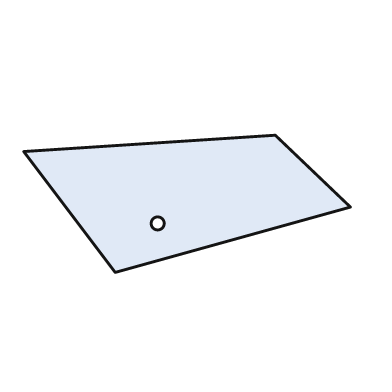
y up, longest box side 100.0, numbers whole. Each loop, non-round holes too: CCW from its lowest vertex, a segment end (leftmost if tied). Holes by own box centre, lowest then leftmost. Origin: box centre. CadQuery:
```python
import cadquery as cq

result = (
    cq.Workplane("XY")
    .moveTo(-22.0, -21.0)
    .lineTo(50.0, -1.0)
    .lineTo(27.0, 21.0)
    .lineTo(-50.0, 16.0)
    .close()
    .moveTo(-9.0, -6.0)
    .circle(2.0)
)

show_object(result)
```